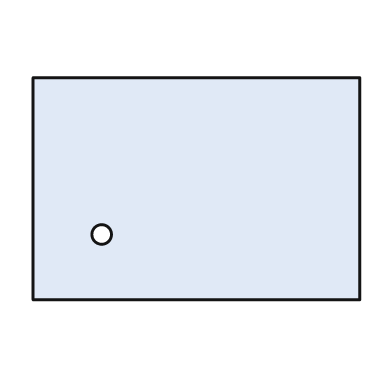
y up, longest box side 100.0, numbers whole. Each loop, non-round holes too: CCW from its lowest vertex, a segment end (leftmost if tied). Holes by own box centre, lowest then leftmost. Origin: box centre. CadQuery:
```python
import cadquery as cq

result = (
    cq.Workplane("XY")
    .moveTo(-50.0, -34.0)
    .lineTo(50.0, -34.0)
    .lineTo(50.0, 34.0)
    .lineTo(-50.0, 34.0)
    .close()
    .moveTo(-29.0, -14.0)
    .circle(3.0)
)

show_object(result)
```